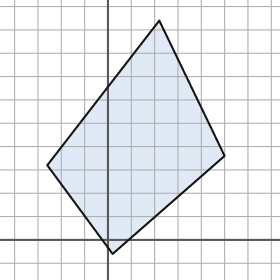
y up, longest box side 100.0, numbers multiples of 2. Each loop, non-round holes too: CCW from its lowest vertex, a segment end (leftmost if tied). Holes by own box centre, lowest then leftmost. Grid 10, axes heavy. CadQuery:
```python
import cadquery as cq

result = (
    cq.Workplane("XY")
    .moveTo(2.0, -6.0)
    .lineTo(50.0, 36.0)
    .lineTo(22.0, 94.0)
    .lineTo(-26.0, 32.0)
    .close()
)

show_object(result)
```